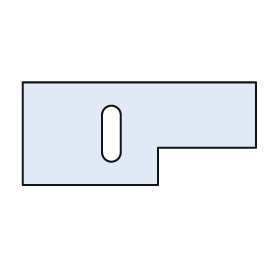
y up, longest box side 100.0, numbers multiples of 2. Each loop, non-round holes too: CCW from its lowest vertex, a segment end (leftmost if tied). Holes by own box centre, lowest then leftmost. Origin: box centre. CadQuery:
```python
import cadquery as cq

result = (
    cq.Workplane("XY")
    .moveTo(-50.0, -22.0)
    .lineTo(8.0, -22.0)
    .lineTo(8.0, -6.0)
    .lineTo(50.0, -6.0)
    .lineTo(50.0, 22.0)
    .lineTo(-50.0, 22.0)
    .close()
    .moveTo(-16.0, -8.0)
    .threePointArc((-12.0, -12.0), (-8.0, -8.0))
    .lineTo(-8.0, 8.0)
    .threePointArc((-12.0, 12.0), (-16.0, 8.0))
    .close()
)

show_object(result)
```